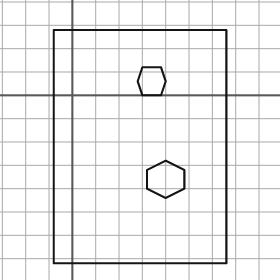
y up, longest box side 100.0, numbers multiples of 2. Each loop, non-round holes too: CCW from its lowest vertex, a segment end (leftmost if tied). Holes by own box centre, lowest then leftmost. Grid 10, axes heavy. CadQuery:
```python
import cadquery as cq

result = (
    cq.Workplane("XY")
    .moveTo(-8.0, -72.0)
    .lineTo(66.0, -72.0)
    .lineTo(66.0, 28.0)
    .lineTo(-8.0, 28.0)
    .close()
    .moveTo(40.0, -44.0)
    .lineTo(48.0, -40.0)
    .lineTo(48.0, -32.0)
    .lineTo(40.0, -28.0)
    .lineTo(32.0, -32.0)
    .lineTo(32.0, -40.0)
    .close()
    .moveTo(30.0, 0.0)
    .lineTo(38.0, 0.0)
    .lineTo(40.0, 6.0)
    .lineTo(38.0, 12.0)
    .lineTo(30.0, 12.0)
    .lineTo(28.0, 6.0)
    .close()
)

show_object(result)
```